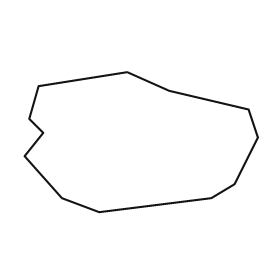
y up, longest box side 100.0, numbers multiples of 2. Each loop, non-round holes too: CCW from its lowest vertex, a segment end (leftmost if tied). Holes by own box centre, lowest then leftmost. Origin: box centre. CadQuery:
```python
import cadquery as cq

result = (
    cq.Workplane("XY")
    .moveTo(-18.0, -30.0)
    .lineTo(30.0, -24.0)
    .lineTo(40.0, -18.0)
    .lineTo(50.0, 2.0)
    .lineTo(46.0, 14.0)
    .lineTo(12.0, 22.0)
    .lineTo(-6.0, 30.0)
    .lineTo(-44.0, 24.0)
    .lineTo(-48.0, 10.0)
    .lineTo(-42.0, 4.0)
    .lineTo(-50.0, -6.0)
    .lineTo(-34.0, -24.0)
    .close()
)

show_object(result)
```